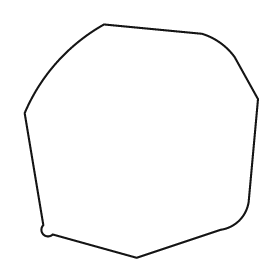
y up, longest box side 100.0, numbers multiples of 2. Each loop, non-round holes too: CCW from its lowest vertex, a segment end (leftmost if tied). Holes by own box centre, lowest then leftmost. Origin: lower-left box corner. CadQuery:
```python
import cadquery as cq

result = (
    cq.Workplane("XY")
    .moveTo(48.0, 0.0)
    .lineTo(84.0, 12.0)
    .threePointArc((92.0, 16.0), (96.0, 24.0))
    .lineTo(100.0, 68.0)
    .lineTo(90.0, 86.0)
    .threePointArc((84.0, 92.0), (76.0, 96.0))
    .lineTo(34.0, 100.0)
    .threePointArc((14.0, 84.0), (0.0, 62.0))
    .lineTo(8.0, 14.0)
    .threePointArc((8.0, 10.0), (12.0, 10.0))
    .close()
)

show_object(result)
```